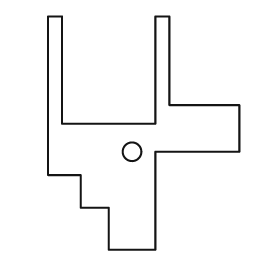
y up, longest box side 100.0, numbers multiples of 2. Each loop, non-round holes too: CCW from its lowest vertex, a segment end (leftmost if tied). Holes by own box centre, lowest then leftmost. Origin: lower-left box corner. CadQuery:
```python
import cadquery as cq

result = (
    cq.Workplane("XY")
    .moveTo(26.0, 0.0)
    .lineTo(46.0, 0.0)
    .lineTo(46.0, 42.0)
    .lineTo(82.0, 42.0)
    .lineTo(82.0, 62.0)
    .lineTo(52.0, 62.0)
    .lineTo(52.0, 100.0)
    .lineTo(46.0, 100.0)
    .lineTo(46.0, 54.0)
    .lineTo(6.0, 54.0)
    .lineTo(6.0, 100.0)
    .lineTo(0.0, 100.0)
    .lineTo(0.0, 32.0)
    .lineTo(14.0, 32.0)
    .lineTo(14.0, 18.0)
    .lineTo(26.0, 18.0)
    .close()
    .moveTo(36.0, 42.0)
    .circle(4.0)
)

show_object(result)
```